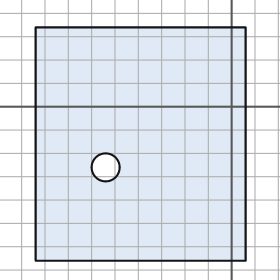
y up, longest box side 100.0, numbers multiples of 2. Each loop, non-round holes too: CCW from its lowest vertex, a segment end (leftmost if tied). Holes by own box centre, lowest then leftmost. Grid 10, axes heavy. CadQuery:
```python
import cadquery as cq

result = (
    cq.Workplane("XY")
    .moveTo(-84.0, -66.0)
    .lineTo(6.0, -66.0)
    .lineTo(6.0, 34.0)
    .lineTo(-84.0, 34.0)
    .close()
    .moveTo(-54.0, -26.0)
    .circle(6.0)
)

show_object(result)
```